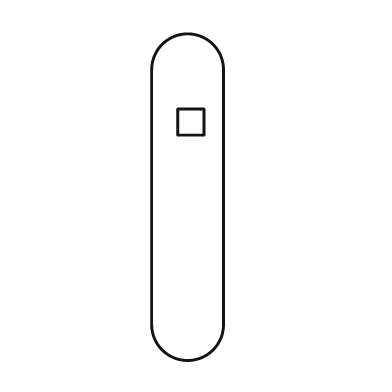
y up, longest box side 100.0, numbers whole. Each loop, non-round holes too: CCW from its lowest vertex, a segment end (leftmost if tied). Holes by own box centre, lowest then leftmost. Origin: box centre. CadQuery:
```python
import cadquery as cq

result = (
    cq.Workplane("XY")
    .moveTo(-11.0, -39.0)
    .threePointArc((0.0, -50.0), (11.0, -39.0))
    .lineTo(11.0, 39.0)
    .threePointArc((0.0, 50.0), (-11.0, 39.0))
    .close()
    .moveTo(-3.0, 19.0)
    .lineTo(5.0, 19.0)
    .lineTo(5.0, 27.0)
    .lineTo(-3.0, 27.0)
    .close()
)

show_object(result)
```